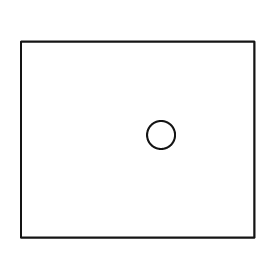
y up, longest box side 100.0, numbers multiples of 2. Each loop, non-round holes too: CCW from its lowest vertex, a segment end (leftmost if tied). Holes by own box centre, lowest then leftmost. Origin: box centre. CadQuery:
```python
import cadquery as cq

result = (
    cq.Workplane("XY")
    .moveTo(-50.0, -42.0)
    .lineTo(50.0, -42.0)
    .lineTo(50.0, 42.0)
    .lineTo(-50.0, 42.0)
    .close()
    .moveTo(10.0, 2.0)
    .circle(6.0)
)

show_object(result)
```